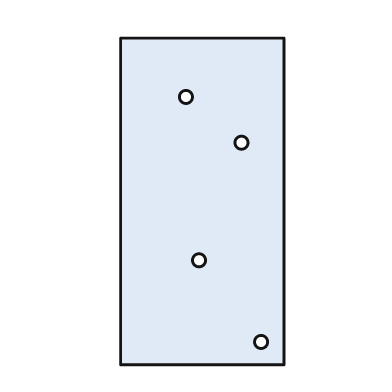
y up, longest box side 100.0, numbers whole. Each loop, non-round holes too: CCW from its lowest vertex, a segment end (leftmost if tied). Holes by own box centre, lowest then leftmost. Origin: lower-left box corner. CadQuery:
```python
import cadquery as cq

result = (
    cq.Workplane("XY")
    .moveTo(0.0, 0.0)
    .lineTo(50.0, 0.0)
    .lineTo(50.0, 100.0)
    .lineTo(0.0, 100.0)
    .close()
    .moveTo(43.0, 7.0)
    .circle(2.0)
    .moveTo(24.0, 32.0)
    .circle(2.0)
    .moveTo(37.0, 68.0)
    .circle(2.0)
    .moveTo(20.0, 82.0)
    .circle(2.0)
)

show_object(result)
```